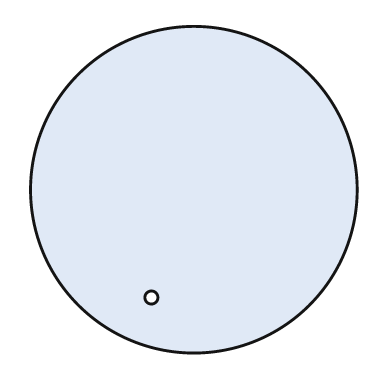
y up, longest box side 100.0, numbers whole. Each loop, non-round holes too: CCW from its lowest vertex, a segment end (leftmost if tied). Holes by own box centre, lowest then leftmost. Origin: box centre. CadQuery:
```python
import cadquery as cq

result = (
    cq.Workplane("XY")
    .moveTo(0.0, 0.0)
    .circle(50.0)
    .moveTo(-13.0, -33.0)
    .circle(2.0)
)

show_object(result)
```